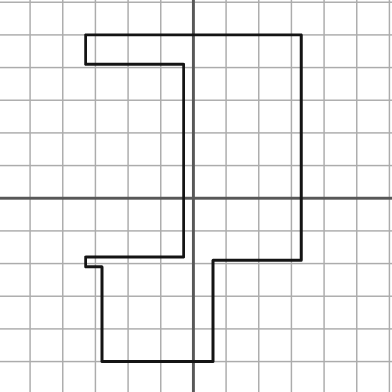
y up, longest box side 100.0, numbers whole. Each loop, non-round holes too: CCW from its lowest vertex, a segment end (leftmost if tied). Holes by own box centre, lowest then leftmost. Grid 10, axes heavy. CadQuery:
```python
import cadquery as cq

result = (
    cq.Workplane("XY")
    .moveTo(-28.0, -50.0)
    .lineTo(6.0, -50.0)
    .lineTo(6.0, -19.0)
    .lineTo(33.0, -19.0)
    .lineTo(33.0, 50.0)
    .lineTo(-33.0, 50.0)
    .lineTo(-33.0, 41.0)
    .lineTo(-3.0, 41.0)
    .lineTo(-3.0, -18.0)
    .lineTo(-33.0, -18.0)
    .lineTo(-33.0, -21.0)
    .lineTo(-28.0, -21.0)
    .close()
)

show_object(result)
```